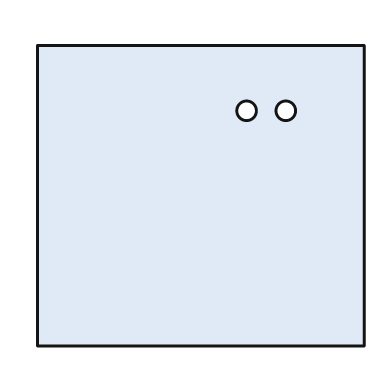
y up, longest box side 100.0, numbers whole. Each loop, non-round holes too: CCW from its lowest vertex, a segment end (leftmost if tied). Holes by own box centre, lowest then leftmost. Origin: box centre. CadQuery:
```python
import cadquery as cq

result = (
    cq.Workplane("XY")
    .moveTo(-50.0, -46.0)
    .lineTo(50.0, -46.0)
    .lineTo(50.0, 46.0)
    .lineTo(-50.0, 46.0)
    .close()
    .moveTo(14.0, 26.0)
    .circle(3.0)
    .moveTo(26.0, 26.0)
    .circle(3.0)
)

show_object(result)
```